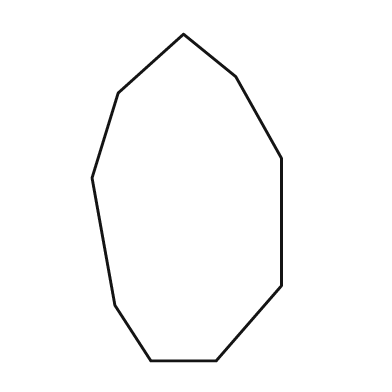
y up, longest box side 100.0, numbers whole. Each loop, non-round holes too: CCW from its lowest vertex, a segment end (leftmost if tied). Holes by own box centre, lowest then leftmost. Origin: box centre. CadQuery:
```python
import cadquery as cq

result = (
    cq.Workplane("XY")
    .moveTo(-11.0, -50.0)
    .lineTo(9.0, -50.0)
    .lineTo(29.0, -27.0)
    .lineTo(29.0, 12.0)
    .lineTo(15.0, 37.0)
    .lineTo(-1.0, 50.0)
    .lineTo(-21.0, 32.0)
    .lineTo(-29.0, 6.0)
    .lineTo(-22.0, -33.0)
    .close()
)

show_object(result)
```